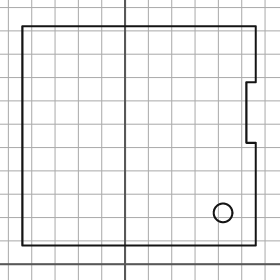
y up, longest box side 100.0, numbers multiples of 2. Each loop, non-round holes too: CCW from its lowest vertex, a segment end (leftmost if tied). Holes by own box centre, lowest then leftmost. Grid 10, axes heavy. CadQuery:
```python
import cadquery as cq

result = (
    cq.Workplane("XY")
    .moveTo(-44.0, 8.0)
    .lineTo(56.0, 8.0)
    .lineTo(56.0, 52.0)
    .lineTo(52.0, 52.0)
    .lineTo(52.0, 78.0)
    .lineTo(56.0, 78.0)
    .lineTo(56.0, 102.0)
    .lineTo(-44.0, 102.0)
    .close()
    .moveTo(42.0, 22.0)
    .circle(4.0)
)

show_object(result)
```